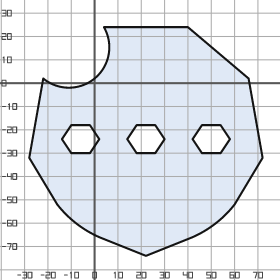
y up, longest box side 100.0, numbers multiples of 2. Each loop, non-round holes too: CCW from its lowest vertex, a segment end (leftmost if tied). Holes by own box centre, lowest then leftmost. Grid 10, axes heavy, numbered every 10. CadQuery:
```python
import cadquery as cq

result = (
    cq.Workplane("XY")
    .moveTo(22.0, -74.0)
    .lineTo(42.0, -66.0)
    .threePointArc((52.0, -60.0), (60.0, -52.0))
    .lineTo(72.0, -32.0)
    .lineTo(66.0, 2.0)
    .lineTo(40.0, 24.0)
    .lineTo(4.0, 24.0)
    .threePointArc((0.0, 2.0), (-22.0, 2.0))
    .lineTo(-28.0, -32.0)
    .lineTo(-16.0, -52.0)
    .threePointArc((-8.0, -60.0), (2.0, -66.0))
    .close()
    .moveTo(-10.0, -30.0)
    .lineTo(-2.0, -30.0)
    .lineTo(2.0, -24.0)
    .lineTo(-2.0, -18.0)
    .lineTo(-10.0, -18.0)
    .lineTo(-14.0, -24.0)
    .close()
    .moveTo(18.0, -30.0)
    .lineTo(26.0, -30.0)
    .lineTo(30.0, -24.0)
    .lineTo(26.0, -18.0)
    .lineTo(18.0, -18.0)
    .lineTo(14.0, -24.0)
    .close()
    .moveTo(46.0, -30.0)
    .lineTo(54.0, -30.0)
    .lineTo(58.0, -24.0)
    .lineTo(54.0, -18.0)
    .lineTo(46.0, -18.0)
    .lineTo(42.0, -24.0)
    .close()
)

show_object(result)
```